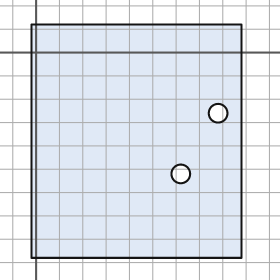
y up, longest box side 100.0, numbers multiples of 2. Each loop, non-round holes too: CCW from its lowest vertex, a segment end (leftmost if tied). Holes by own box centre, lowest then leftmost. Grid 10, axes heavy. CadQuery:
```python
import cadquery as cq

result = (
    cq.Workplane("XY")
    .moveTo(-2.0, -88.0)
    .lineTo(88.0, -88.0)
    .lineTo(88.0, 12.0)
    .lineTo(-2.0, 12.0)
    .close()
    .moveTo(62.0, -52.0)
    .circle(4.0)
    .moveTo(78.0, -26.0)
    .circle(4.0)
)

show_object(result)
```